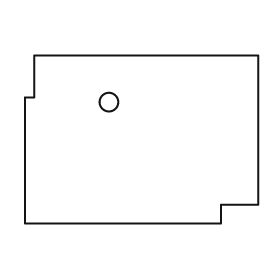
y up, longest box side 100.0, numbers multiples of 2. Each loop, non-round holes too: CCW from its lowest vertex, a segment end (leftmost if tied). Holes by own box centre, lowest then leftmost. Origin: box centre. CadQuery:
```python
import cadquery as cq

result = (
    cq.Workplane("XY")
    .moveTo(-50.0, -36.0)
    .lineTo(34.0, -36.0)
    .lineTo(34.0, -28.0)
    .lineTo(50.0, -28.0)
    .lineTo(50.0, 36.0)
    .lineTo(-46.0, 36.0)
    .lineTo(-46.0, 18.0)
    .lineTo(-50.0, 18.0)
    .close()
    .moveTo(-14.0, 16.0)
    .circle(4.0)
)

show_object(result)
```